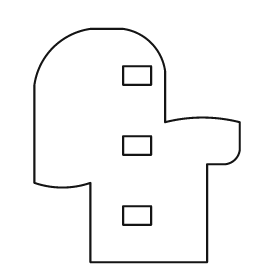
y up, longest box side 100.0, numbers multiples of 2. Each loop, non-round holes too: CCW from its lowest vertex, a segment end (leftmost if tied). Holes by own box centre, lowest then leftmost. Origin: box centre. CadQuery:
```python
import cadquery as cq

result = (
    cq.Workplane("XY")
    .moveTo(-20.0, -50.0)
    .lineTo(30.0, -50.0)
    .lineTo(30.0, -8.0)
    .lineTo(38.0, -8.0)
    .threePointArc((42.0, -6.0), (44.0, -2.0))
    .lineTo(44.0, 10.0)
    .threePointArc((28.0, 12.0), (12.0, 10.0))
    .lineTo(12.0, 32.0)
    .threePointArc((6.0, 44.0), (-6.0, 50.0))
    .lineTo(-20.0, 50.0)
    .threePointArc((-36.0, 42.0), (-44.0, 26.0))
    .lineTo(-44.0, -16.0)
    .threePointArc((-32.0, -18.0), (-20.0, -16.0))
    .close()
    .moveTo(-6.0, -34.0)
    .lineTo(6.0, -34.0)
    .lineTo(6.0, -26.0)
    .lineTo(-6.0, -26.0)
    .close()
    .moveTo(-6.0, -4.0)
    .lineTo(6.0, -4.0)
    .lineTo(6.0, 4.0)
    .lineTo(-6.0, 4.0)
    .close()
    .moveTo(-6.0, 26.0)
    .lineTo(6.0, 26.0)
    .lineTo(6.0, 34.0)
    .lineTo(-6.0, 34.0)
    .close()
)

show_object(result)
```